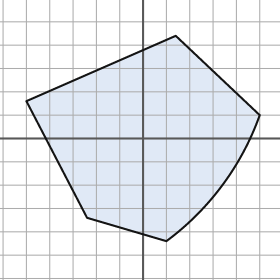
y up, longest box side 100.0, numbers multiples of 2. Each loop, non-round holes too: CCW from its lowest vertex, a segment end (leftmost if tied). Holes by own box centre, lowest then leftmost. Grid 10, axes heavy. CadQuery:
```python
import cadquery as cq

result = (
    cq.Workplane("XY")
    .moveTo(10.0, -44.0)
    .threePointArc((34.0, -20.0), (50.0, 10.0))
    .lineTo(14.0, 44.0)
    .lineTo(-50.0, 16.0)
    .lineTo(-24.0, -34.0)
    .close()
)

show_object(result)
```